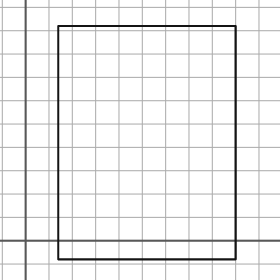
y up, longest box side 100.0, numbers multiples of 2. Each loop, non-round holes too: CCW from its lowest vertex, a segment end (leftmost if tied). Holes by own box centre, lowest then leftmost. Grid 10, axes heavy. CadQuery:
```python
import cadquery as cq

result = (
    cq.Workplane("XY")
    .moveTo(14.0, -8.0)
    .lineTo(90.0, -8.0)
    .lineTo(90.0, 92.0)
    .lineTo(14.0, 92.0)
    .close()
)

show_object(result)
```